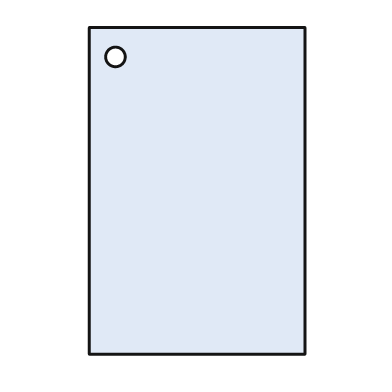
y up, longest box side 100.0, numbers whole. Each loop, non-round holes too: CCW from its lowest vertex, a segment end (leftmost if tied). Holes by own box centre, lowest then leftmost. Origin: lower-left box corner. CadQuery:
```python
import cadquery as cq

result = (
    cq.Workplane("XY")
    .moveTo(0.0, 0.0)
    .lineTo(66.0, 0.0)
    .lineTo(66.0, 100.0)
    .lineTo(0.0, 100.0)
    .close()
    .moveTo(8.0, 91.0)
    .circle(3.0)
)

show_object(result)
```